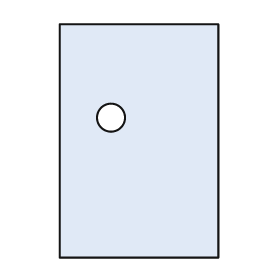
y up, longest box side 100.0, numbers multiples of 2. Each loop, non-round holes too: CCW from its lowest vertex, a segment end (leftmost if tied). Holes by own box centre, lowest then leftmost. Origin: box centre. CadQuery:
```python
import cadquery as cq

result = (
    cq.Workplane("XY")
    .moveTo(-34.0, -50.0)
    .lineTo(34.0, -50.0)
    .lineTo(34.0, 50.0)
    .lineTo(-34.0, 50.0)
    .close()
    .moveTo(-12.0, 10.0)
    .circle(6.0)
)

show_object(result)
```